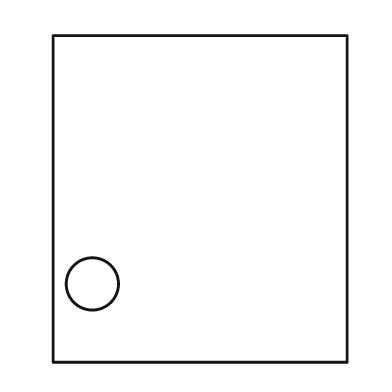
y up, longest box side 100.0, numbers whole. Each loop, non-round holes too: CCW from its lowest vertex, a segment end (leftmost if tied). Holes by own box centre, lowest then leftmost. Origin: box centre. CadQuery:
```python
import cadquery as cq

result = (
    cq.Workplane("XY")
    .moveTo(-45.0, -50.0)
    .lineTo(45.0, -50.0)
    .lineTo(45.0, 50.0)
    .lineTo(-45.0, 50.0)
    .close()
    .moveTo(-33.0, -26.0)
    .circle(8.0)
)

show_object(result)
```